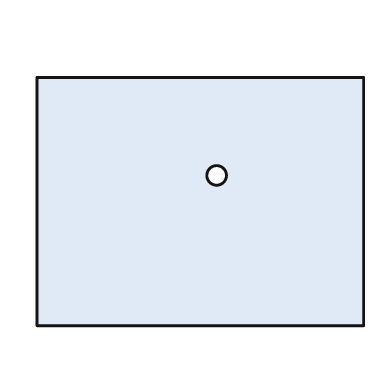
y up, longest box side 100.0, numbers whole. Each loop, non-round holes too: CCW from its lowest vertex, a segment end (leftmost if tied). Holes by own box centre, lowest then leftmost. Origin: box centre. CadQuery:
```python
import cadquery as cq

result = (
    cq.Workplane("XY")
    .moveTo(-50.0, -38.0)
    .lineTo(50.0, -38.0)
    .lineTo(50.0, 38.0)
    .lineTo(-50.0, 38.0)
    .close()
    .moveTo(5.0, 8.0)
    .circle(3.0)
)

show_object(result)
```